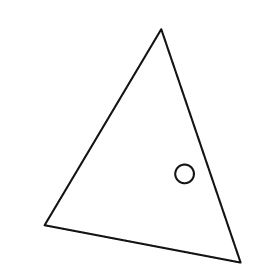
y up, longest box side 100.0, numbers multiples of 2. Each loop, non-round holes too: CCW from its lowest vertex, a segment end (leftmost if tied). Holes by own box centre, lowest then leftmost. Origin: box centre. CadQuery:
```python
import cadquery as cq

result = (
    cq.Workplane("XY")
    .moveTo(42.0, -50.0)
    .lineTo(8.0, 50.0)
    .lineTo(-42.0, -34.0)
    .close()
    .moveTo(18.0, -12.0)
    .circle(4.0)
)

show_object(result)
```